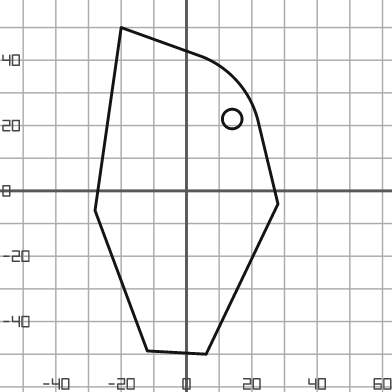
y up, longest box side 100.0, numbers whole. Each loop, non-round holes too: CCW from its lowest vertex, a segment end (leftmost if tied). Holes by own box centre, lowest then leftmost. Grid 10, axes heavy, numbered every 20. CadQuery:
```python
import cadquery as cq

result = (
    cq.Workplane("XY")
    .moveTo(6.0, -50.0)
    .lineTo(28.0, -4.0)
    .lineTo(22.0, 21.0)
    .threePointArc((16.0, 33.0), (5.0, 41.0))
    .lineTo(-20.0, 50.0)
    .lineTo(-28.0, -6.0)
    .lineTo(-12.0, -49.0)
    .close()
    .moveTo(14.0, 22.0)
    .circle(3.0)
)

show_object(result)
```